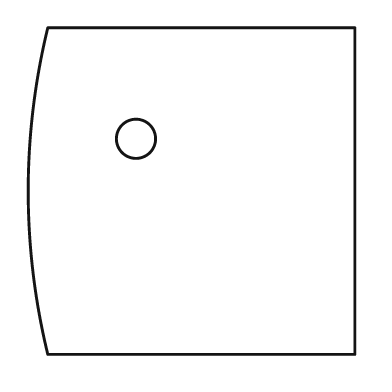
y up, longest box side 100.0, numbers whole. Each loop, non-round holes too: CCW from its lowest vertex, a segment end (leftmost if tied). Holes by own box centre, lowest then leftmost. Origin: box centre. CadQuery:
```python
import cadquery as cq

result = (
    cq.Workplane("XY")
    .moveTo(-44.0, -50.0)
    .lineTo(50.0, -50.0)
    .lineTo(50.0, 50.0)
    .lineTo(-44.0, 50.0)
    .threePointArc((-50.0, 0.0), (-44.0, -50.0))
    .close()
    .moveTo(-17.0, 16.0)
    .circle(6.0)
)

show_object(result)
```